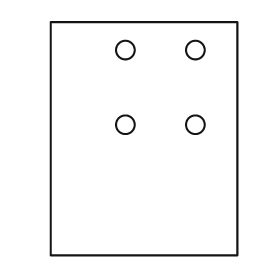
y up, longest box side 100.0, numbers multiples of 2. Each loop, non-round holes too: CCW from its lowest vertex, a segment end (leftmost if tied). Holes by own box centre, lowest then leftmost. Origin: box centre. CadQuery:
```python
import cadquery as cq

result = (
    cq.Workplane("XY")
    .moveTo(-40.0, -50.0)
    .lineTo(40.0, -50.0)
    .lineTo(40.0, 50.0)
    .lineTo(-40.0, 50.0)
    .close()
    .moveTo(-8.0, 6.0)
    .circle(4.0)
    .moveTo(22.0, 6.0)
    .circle(4.0)
    .moveTo(-8.0, 38.0)
    .circle(4.0)
    .moveTo(22.0, 38.0)
    .circle(4.0)
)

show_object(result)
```